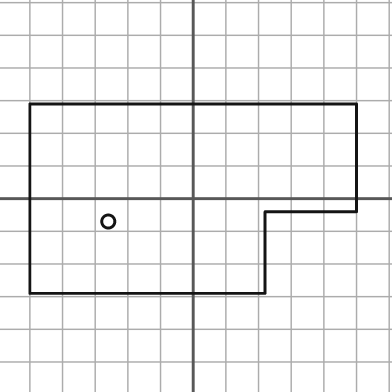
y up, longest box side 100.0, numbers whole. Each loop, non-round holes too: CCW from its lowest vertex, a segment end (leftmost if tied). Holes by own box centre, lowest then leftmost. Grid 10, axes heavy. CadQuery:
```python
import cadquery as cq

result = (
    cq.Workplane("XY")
    .moveTo(-50.0, -29.0)
    .lineTo(22.0, -29.0)
    .lineTo(22.0, -4.0)
    .lineTo(50.0, -4.0)
    .lineTo(50.0, 29.0)
    .lineTo(-50.0, 29.0)
    .close()
    .moveTo(-26.0, -7.0)
    .circle(2.0)
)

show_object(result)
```